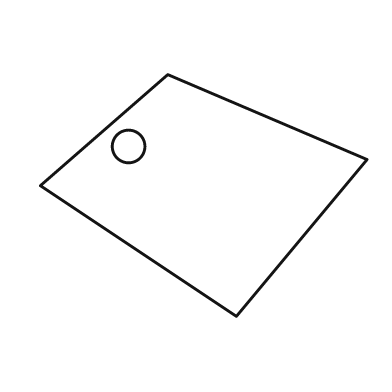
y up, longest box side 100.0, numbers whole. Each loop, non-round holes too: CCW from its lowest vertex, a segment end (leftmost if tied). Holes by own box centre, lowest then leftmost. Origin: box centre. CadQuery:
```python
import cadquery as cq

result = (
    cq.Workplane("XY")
    .moveTo(10.0, -37.0)
    .lineTo(50.0, 11.0)
    .lineTo(-11.0, 37.0)
    .lineTo(-50.0, 3.0)
    .close()
    .moveTo(-23.0, 15.0)
    .circle(5.0)
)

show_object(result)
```